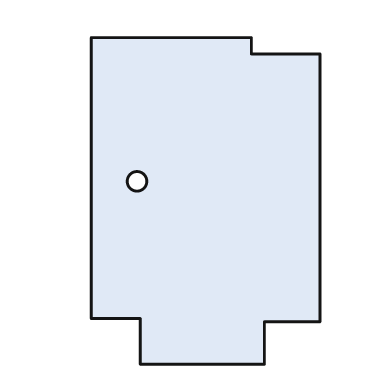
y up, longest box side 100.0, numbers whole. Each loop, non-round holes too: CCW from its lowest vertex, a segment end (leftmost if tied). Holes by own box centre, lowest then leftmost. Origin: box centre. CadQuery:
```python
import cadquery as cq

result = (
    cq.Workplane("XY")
    .moveTo(-20.0, -50.0)
    .lineTo(18.0, -50.0)
    .lineTo(18.0, -37.0)
    .lineTo(35.0, -37.0)
    .lineTo(35.0, 45.0)
    .lineTo(14.0, 45.0)
    .lineTo(14.0, 50.0)
    .lineTo(-35.0, 50.0)
    .lineTo(-35.0, -36.0)
    .lineTo(-20.0, -36.0)
    .close()
    .moveTo(-21.0, 6.0)
    .circle(3.0)
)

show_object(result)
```